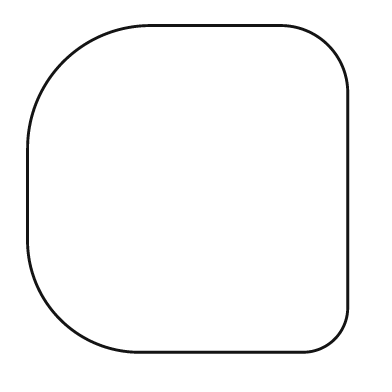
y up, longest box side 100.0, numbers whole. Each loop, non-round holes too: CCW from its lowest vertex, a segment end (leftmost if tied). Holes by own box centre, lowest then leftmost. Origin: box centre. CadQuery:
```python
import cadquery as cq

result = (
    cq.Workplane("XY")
    .moveTo(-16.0, -50.0)
    .lineTo(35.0, -50.0)
    .threePointArc((45.0, -46.0), (49.0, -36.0))
    .lineTo(49.0, 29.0)
    .threePointArc((43.0, 44.0), (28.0, 50.0))
    .lineTo(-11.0, 50.0)
    .threePointArc((-38.0, 39.0), (-49.0, 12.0))
    .lineTo(-49.0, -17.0)
    .threePointArc((-39.0, -40.0), (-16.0, -50.0))
    .close()
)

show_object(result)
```